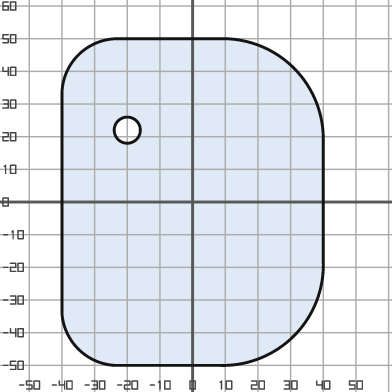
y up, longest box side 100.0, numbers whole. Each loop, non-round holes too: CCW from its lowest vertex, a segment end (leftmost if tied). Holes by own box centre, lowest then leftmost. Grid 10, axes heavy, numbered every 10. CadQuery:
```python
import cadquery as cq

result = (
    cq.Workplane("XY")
    .moveTo(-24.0, -50.0)
    .lineTo(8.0, -50.0)
    .threePointArc((31.0, -41.0), (40.0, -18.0))
    .lineTo(40.0, 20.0)
    .threePointArc((31.0, 41.0), (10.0, 50.0))
    .lineTo(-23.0, 50.0)
    .threePointArc((-35.0, 45.0), (-40.0, 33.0))
    .lineTo(-40.0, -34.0)
    .threePointArc((-35.0, -45.0), (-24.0, -50.0))
    .close()
    .moveTo(-20.0, 22.0)
    .circle(4.0)
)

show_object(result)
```